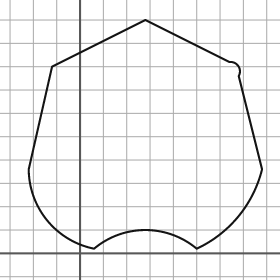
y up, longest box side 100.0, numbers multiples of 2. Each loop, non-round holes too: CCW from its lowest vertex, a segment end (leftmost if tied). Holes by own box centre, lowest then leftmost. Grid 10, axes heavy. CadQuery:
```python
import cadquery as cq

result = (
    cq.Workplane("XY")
    .moveTo(6.0, 2.0)
    .threePointArc((28.0, 10.0), (50.0, 2.0))
    .threePointArc((68.0, 16.0), (78.0, 36.0))
    .lineTo(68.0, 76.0)
    .threePointArc((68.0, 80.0), (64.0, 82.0))
    .lineTo(28.0, 100.0)
    .lineTo(-12.0, 80.0)
    .lineTo(-22.0, 36.0)
    .threePointArc((-14.0, 14.0), (6.0, 2.0))
    .close()
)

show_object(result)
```